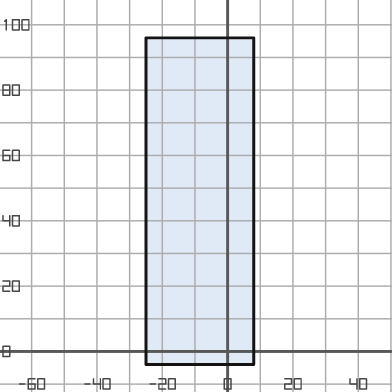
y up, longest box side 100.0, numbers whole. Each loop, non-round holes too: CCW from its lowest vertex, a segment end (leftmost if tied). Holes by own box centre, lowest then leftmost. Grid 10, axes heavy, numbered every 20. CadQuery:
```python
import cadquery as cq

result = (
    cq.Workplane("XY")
    .moveTo(-25.0, -4.0)
    .lineTo(8.0, -4.0)
    .lineTo(8.0, 96.0)
    .lineTo(-25.0, 96.0)
    .close()
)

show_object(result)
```